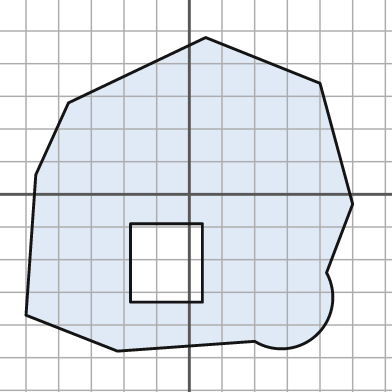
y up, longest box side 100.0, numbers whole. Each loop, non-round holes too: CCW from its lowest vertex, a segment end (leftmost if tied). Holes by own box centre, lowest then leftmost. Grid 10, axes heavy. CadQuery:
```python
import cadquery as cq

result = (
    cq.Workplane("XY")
    .moveTo(-22.0, -48.0)
    .lineTo(20.0, -45.0)
    .threePointArc((39.0, -43.0), (42.0, -24.0))
    .lineTo(50.0, -3.0)
    .lineTo(40.0, 34.0)
    .lineTo(5.0, 48.0)
    .lineTo(-37.0, 28.0)
    .lineTo(-47.0, 6.0)
    .lineTo(-50.0, -37.0)
    .close()
    .moveTo(-18.0, -33.0)
    .lineTo(4.0, -33.0)
    .lineTo(4.0, -9.0)
    .lineTo(-18.0, -9.0)
    .close()
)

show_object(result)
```